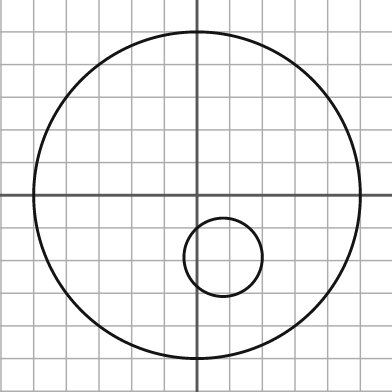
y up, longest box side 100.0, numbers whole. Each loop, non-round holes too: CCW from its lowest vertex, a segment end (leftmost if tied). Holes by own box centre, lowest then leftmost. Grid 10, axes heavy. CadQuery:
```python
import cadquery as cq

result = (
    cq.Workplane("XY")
    .moveTo(0.0, 0.0)
    .circle(50.0)
    .moveTo(8.0, -19.0)
    .circle(12.0)
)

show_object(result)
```